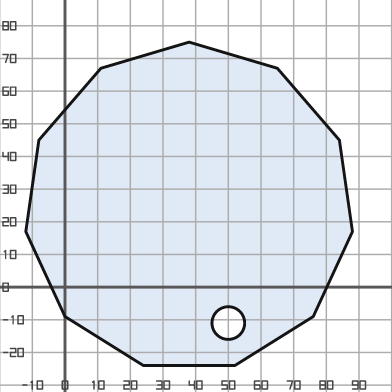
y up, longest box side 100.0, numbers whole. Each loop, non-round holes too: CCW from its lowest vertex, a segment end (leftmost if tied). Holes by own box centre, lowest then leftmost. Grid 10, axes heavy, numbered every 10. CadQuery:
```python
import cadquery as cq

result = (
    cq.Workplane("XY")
    .moveTo(24.0, -24.0)
    .lineTo(52.0, -24.0)
    .lineTo(76.0, -9.0)
    .lineTo(88.0, 17.0)
    .lineTo(84.0, 45.0)
    .lineTo(65.0, 67.0)
    .lineTo(38.0, 75.0)
    .lineTo(11.0, 67.0)
    .lineTo(-8.0, 45.0)
    .lineTo(-12.0, 17.0)
    .lineTo(0.0, -9.0)
    .close()
    .moveTo(50.0, -11.0)
    .circle(5.0)
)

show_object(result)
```